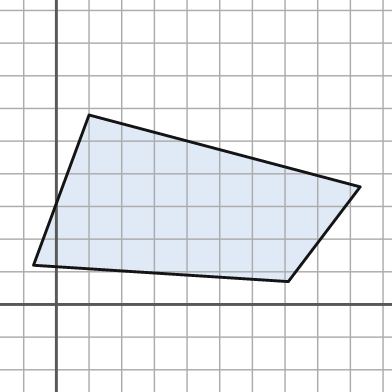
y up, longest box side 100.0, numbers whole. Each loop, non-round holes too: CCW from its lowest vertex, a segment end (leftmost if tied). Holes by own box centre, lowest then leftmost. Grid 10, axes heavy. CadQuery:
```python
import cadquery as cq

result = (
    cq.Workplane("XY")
    .moveTo(71.0, 7.0)
    .lineTo(93.0, 36.0)
    .lineTo(10.0, 58.0)
    .lineTo(-7.0, 12.0)
    .close()
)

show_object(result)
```